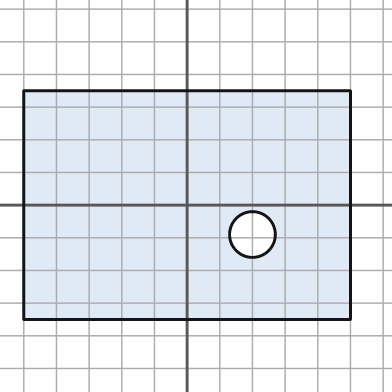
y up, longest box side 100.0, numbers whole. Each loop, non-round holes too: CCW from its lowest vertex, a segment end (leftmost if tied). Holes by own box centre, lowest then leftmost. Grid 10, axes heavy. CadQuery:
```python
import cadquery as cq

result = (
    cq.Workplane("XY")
    .moveTo(-50.0, -35.0)
    .lineTo(50.0, -35.0)
    .lineTo(50.0, 35.0)
    .lineTo(-50.0, 35.0)
    .close()
    .moveTo(20.0, -9.0)
    .circle(7.0)
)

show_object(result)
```